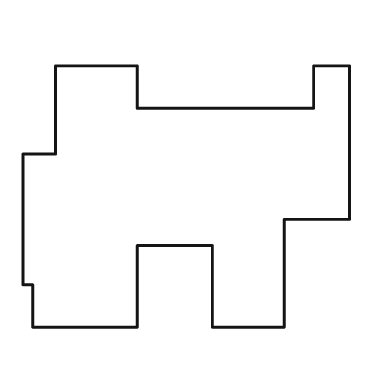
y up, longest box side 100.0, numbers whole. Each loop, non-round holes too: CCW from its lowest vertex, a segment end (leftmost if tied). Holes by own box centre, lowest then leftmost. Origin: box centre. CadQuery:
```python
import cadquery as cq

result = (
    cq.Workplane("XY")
    .moveTo(-47.0, -40.0)
    .lineTo(-15.0, -40.0)
    .lineTo(-15.0, -15.0)
    .lineTo(8.0, -15.0)
    .lineTo(8.0, -40.0)
    .lineTo(30.0, -40.0)
    .lineTo(30.0, -7.0)
    .lineTo(50.0, -7.0)
    .lineTo(50.0, 40.0)
    .lineTo(39.0, 40.0)
    .lineTo(39.0, 27.0)
    .lineTo(-15.0, 27.0)
    .lineTo(-15.0, 40.0)
    .lineTo(-40.0, 40.0)
    .lineTo(-40.0, 13.0)
    .lineTo(-50.0, 13.0)
    .lineTo(-50.0, -27.0)
    .lineTo(-47.0, -27.0)
    .close()
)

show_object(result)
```